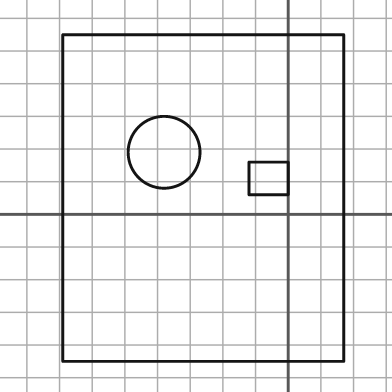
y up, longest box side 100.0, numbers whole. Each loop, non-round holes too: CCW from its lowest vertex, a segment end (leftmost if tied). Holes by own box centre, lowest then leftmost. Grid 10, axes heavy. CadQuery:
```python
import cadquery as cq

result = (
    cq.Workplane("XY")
    .moveTo(-69.0, -45.0)
    .lineTo(17.0, -45.0)
    .lineTo(17.0, 55.0)
    .lineTo(-69.0, 55.0)
    .close()
    .moveTo(-12.0, 6.0)
    .lineTo(0.0, 6.0)
    .lineTo(0.0, 16.0)
    .lineTo(-12.0, 16.0)
    .close()
    .moveTo(-38.0, 19.0)
    .circle(11.0)
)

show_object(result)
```